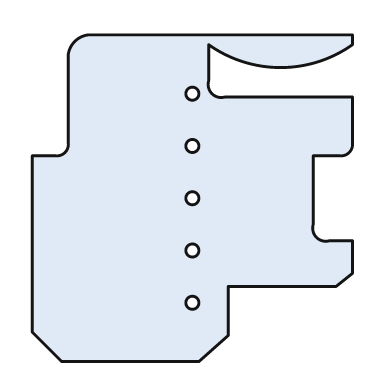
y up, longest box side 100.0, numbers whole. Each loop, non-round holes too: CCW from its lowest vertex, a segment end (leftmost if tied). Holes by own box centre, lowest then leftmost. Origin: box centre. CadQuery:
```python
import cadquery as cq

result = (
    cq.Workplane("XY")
    .moveTo(-40.0, -50.0)
    .lineTo(2.0, -50.0)
    .lineTo(11.0, -42.0)
    .lineTo(11.0, -27.0)
    .lineTo(44.0, -27.0)
    .lineTo(49.0, -23.0)
    .lineTo(49.0, -13.0)
    .lineTo(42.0, -13.0)
    .threePointArc((38.0, -12.0), (37.0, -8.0))
    .lineTo(37.0, 13.0)
    .lineTo(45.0, 13.0)
    .threePointArc((48.0, 14.0), (49.0, 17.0))
    .lineTo(49.0, 31.0)
    .lineTo(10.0, 31.0)
    .threePointArc((6.0, 32.0), (5.0, 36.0))
    .lineTo(5.0, 47.0)
    .threePointArc((27.0, 40.0), (49.0, 47.0))
    .lineTo(49.0, 50.0)
    .lineTo(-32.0, 50.0)
    .threePointArc((-36.0, 48.0), (-38.0, 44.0))
    .lineTo(-38.0, 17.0)
    .threePointArc((-39.0, 14.0), (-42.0, 13.0))
    .lineTo(-49.0, 13.0)
    .lineTo(-49.0, -41.0)
    .close()
    .moveTo(0.0, -32.0)
    .circle(2.0)
    .moveTo(0.0, -16.0)
    .circle(2.0)
    .moveTo(0.0, 0.0)
    .circle(2.0)
    .moveTo(0.0, 16.0)
    .circle(2.0)
    .moveTo(0.0, 32.0)
    .circle(2.0)
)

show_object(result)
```